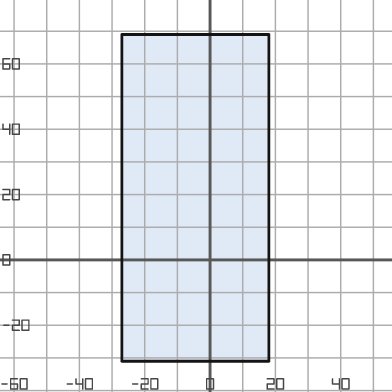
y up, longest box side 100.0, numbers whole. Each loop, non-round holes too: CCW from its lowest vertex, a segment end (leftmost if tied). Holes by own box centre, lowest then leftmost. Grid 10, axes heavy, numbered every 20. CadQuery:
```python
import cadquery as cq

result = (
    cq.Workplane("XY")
    .moveTo(-27.0, -31.0)
    .lineTo(18.0, -31.0)
    .lineTo(18.0, 69.0)
    .lineTo(-27.0, 69.0)
    .close()
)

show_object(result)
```